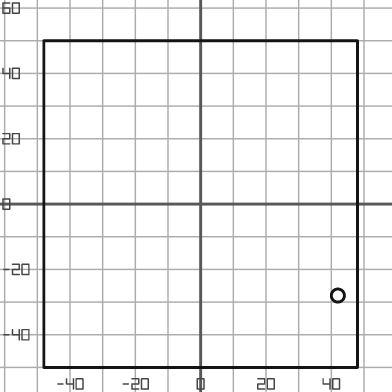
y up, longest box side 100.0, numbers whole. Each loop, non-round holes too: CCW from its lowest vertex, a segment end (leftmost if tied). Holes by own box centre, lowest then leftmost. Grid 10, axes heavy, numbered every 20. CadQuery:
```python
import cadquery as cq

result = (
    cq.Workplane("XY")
    .moveTo(-48.0, -50.0)
    .lineTo(48.0, -50.0)
    .lineTo(48.0, 50.0)
    .lineTo(-48.0, 50.0)
    .close()
    .moveTo(42.0, -28.0)
    .circle(2.0)
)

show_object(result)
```